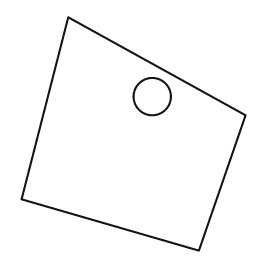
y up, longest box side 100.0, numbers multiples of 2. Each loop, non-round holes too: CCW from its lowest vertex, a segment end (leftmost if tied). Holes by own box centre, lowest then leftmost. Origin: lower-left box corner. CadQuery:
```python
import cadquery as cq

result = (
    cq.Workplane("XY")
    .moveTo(76.0, 0.0)
    .lineTo(96.0, 58.0)
    .lineTo(20.0, 100.0)
    .lineTo(0.0, 22.0)
    .close()
    .moveTo(56.0, 66.0)
    .circle(8.0)
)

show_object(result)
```